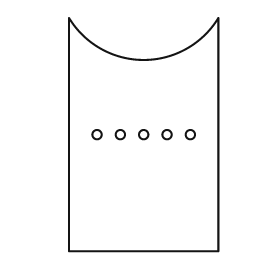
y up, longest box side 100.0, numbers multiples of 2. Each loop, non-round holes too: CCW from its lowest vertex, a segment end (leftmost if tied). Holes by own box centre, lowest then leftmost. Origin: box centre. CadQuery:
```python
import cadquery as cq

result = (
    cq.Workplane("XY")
    .moveTo(-32.0, -50.0)
    .lineTo(32.0, -50.0)
    .lineTo(32.0, 50.0)
    .threePointArc((0.0, 32.0), (-32.0, 50.0))
    .close()
    .moveTo(-20.0, 0.0)
    .circle(2.0)
    .moveTo(-10.0, 0.0)
    .circle(2.0)
    .moveTo(0.0, 0.0)
    .circle(2.0)
    .moveTo(10.0, 0.0)
    .circle(2.0)
    .moveTo(20.0, 0.0)
    .circle(2.0)
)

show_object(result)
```